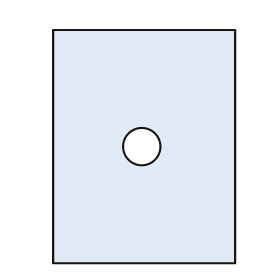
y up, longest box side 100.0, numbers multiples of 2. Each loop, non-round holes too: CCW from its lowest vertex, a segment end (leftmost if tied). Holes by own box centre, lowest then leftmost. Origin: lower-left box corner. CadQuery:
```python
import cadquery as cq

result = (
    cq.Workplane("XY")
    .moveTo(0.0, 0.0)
    .lineTo(78.0, 0.0)
    .lineTo(78.0, 100.0)
    .lineTo(0.0, 100.0)
    .close()
    .moveTo(38.0, 50.0)
    .circle(8.0)
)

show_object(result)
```